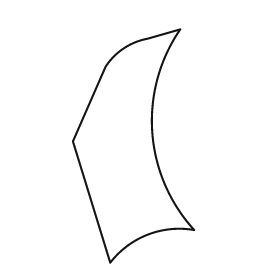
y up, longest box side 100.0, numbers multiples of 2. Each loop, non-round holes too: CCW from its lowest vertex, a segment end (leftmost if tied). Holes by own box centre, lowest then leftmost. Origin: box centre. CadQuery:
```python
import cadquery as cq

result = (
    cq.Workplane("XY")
    .moveTo(-10.0, -50.0)
    .threePointArc((6.0, -38.0), (26.0, -36.0))
    .threePointArc((8.0, 6.0), (20.0, 50.0))
    .lineTo(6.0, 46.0)
    .threePointArc((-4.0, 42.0), (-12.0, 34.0))
    .lineTo(-26.0, 2.0)
    .close()
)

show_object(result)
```